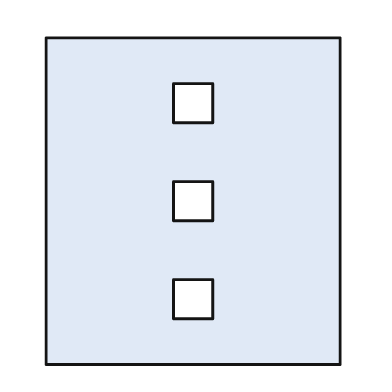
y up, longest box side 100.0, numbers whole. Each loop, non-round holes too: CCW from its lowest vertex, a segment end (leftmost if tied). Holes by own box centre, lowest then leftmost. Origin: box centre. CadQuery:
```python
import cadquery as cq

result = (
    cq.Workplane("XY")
    .moveTo(-45.0, -50.0)
    .lineTo(45.0, -50.0)
    .lineTo(45.0, 50.0)
    .lineTo(-45.0, 50.0)
    .close()
    .moveTo(-6.0, -36.0)
    .lineTo(6.0, -36.0)
    .lineTo(6.0, -24.0)
    .lineTo(-6.0, -24.0)
    .close()
    .moveTo(-6.0, -6.0)
    .lineTo(6.0, -6.0)
    .lineTo(6.0, 6.0)
    .lineTo(-6.0, 6.0)
    .close()
    .moveTo(-6.0, 24.0)
    .lineTo(6.0, 24.0)
    .lineTo(6.0, 36.0)
    .lineTo(-6.0, 36.0)
    .close()
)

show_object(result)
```